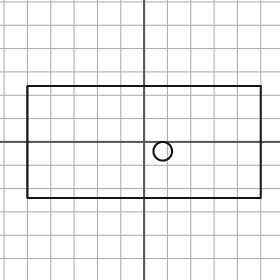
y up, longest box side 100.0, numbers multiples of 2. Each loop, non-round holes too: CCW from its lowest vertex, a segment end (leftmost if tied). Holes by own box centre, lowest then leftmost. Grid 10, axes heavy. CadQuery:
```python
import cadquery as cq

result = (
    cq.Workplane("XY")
    .moveTo(-50.0, -24.0)
    .lineTo(50.0, -24.0)
    .lineTo(50.0, 24.0)
    .lineTo(-50.0, 24.0)
    .close()
    .moveTo(8.0, -4.0)
    .circle(4.0)
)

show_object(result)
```